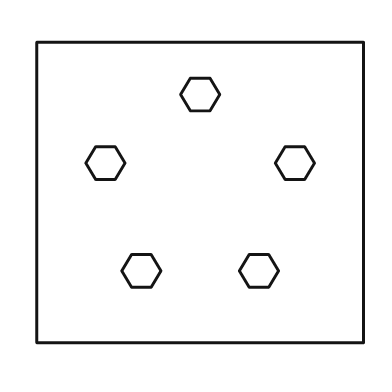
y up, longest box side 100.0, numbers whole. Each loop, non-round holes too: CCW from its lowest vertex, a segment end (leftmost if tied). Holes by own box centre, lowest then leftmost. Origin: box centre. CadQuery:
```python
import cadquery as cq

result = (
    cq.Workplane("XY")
    .moveTo(-50.0, -46.0)
    .lineTo(50.0, -46.0)
    .lineTo(50.0, 46.0)
    .lineTo(-50.0, 46.0)
    .close()
    .moveTo(-21.0, -29.0)
    .lineTo(-15.0, -29.0)
    .lineTo(-12.0, -24.0)
    .lineTo(-15.0, -19.0)
    .lineTo(-21.0, -19.0)
    .lineTo(-24.0, -24.0)
    .close()
    .moveTo(15.0, -29.0)
    .lineTo(21.0, -29.0)
    .lineTo(24.0, -24.0)
    .lineTo(21.0, -19.0)
    .lineTo(15.0, -19.0)
    .lineTo(12.0, -24.0)
    .close()
    .moveTo(-32.0, 4.0)
    .lineTo(-26.0, 4.0)
    .lineTo(-23.0, 9.0)
    .lineTo(-26.0, 14.0)
    .lineTo(-32.0, 14.0)
    .lineTo(-35.0, 9.0)
    .close()
    .moveTo(26.0, 4.0)
    .lineTo(32.0, 4.0)
    .lineTo(35.0, 9.0)
    .lineTo(32.0, 14.0)
    .lineTo(26.0, 14.0)
    .lineTo(23.0, 9.0)
    .close()
    .moveTo(-3.0, 25.0)
    .lineTo(3.0, 25.0)
    .lineTo(6.0, 30.0)
    .lineTo(3.0, 35.0)
    .lineTo(-3.0, 35.0)
    .lineTo(-6.0, 30.0)
    .close()
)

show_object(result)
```